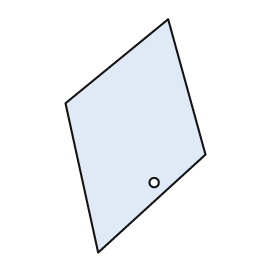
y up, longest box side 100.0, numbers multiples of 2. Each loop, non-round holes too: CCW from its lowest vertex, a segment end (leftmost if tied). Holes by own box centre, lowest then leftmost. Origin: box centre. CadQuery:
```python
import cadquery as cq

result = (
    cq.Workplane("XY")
    .moveTo(-16.0, -50.0)
    .lineTo(30.0, -8.0)
    .lineTo(14.0, 50.0)
    .lineTo(-30.0, 14.0)
    .close()
    .moveTo(8.0, -20.0)
    .circle(2.0)
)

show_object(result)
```